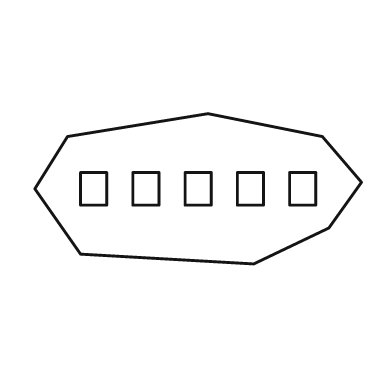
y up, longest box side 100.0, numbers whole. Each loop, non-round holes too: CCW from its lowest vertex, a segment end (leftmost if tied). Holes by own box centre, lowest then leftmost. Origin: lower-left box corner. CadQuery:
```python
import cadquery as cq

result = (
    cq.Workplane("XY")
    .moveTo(67.0, 0.0)
    .lineTo(90.0, 11.0)
    .lineTo(100.0, 25.0)
    .lineTo(88.0, 39.0)
    .lineTo(53.0, 46.0)
    .lineTo(10.0, 39.0)
    .lineTo(0.0, 23.0)
    .lineTo(14.0, 3.0)
    .close()
    .moveTo(14.0, 18.0)
    .lineTo(22.0, 18.0)
    .lineTo(22.0, 28.0)
    .lineTo(14.0, 28.0)
    .close()
    .moveTo(30.0, 18.0)
    .lineTo(38.0, 18.0)
    .lineTo(38.0, 28.0)
    .lineTo(30.0, 28.0)
    .close()
    .moveTo(46.0, 18.0)
    .lineTo(54.0, 18.0)
    .lineTo(54.0, 28.0)
    .lineTo(46.0, 28.0)
    .close()
    .moveTo(62.0, 18.0)
    .lineTo(70.0, 18.0)
    .lineTo(70.0, 28.0)
    .lineTo(62.0, 28.0)
    .close()
    .moveTo(78.0, 18.0)
    .lineTo(86.0, 18.0)
    .lineTo(86.0, 28.0)
    .lineTo(78.0, 28.0)
    .close()
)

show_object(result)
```